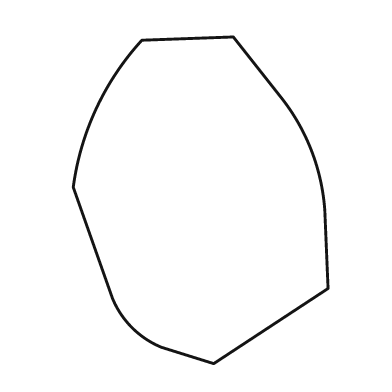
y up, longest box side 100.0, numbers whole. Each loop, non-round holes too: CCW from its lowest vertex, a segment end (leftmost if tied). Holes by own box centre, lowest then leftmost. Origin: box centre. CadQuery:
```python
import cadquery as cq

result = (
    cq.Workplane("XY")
    .moveTo(4.0, -50.0)
    .lineTo(39.0, -27.0)
    .lineTo(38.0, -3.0)
    .threePointArc((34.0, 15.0), (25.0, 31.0))
    .lineTo(10.0, 50.0)
    .lineTo(-18.0, 49.0)
    .threePointArc((-32.0, 28.0), (-39.0, 4.0))
    .lineTo(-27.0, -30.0)
    .threePointArc((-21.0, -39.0), (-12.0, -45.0))
    .close()
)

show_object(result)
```